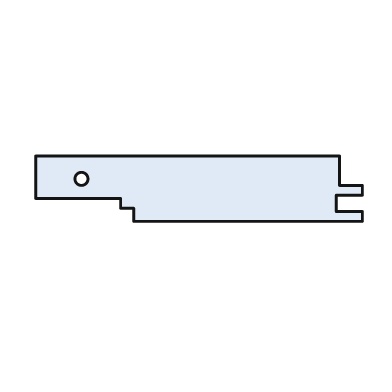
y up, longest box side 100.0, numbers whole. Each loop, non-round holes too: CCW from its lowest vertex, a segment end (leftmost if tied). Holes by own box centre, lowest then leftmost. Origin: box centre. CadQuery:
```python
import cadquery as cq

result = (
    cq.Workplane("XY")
    .moveTo(-20.0, -10.0)
    .lineTo(50.0, -10.0)
    .lineTo(50.0, -7.0)
    .lineTo(42.0, -7.0)
    .lineTo(42.0, -2.0)
    .lineTo(50.0, -2.0)
    .lineTo(50.0, 1.0)
    .lineTo(43.0, 1.0)
    .lineTo(43.0, 10.0)
    .lineTo(-50.0, 10.0)
    .lineTo(-50.0, -3.0)
    .lineTo(-24.0, -3.0)
    .lineTo(-24.0, -6.0)
    .lineTo(-20.0, -6.0)
    .close()
    .moveTo(-36.0, 3.0)
    .circle(2.0)
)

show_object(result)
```